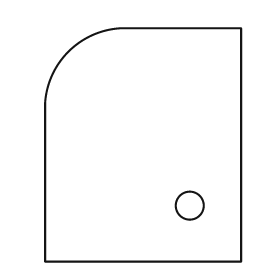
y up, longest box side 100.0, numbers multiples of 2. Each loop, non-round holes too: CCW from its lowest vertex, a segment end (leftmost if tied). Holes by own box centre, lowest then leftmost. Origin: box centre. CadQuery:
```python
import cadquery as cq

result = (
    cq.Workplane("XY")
    .moveTo(-42.0, -50.0)
    .lineTo(42.0, -50.0)
    .lineTo(42.0, 50.0)
    .lineTo(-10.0, 50.0)
    .threePointArc((-32.0, 40.0), (-42.0, 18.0))
    .close()
    .moveTo(20.0, -26.0)
    .circle(6.0)
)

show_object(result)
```